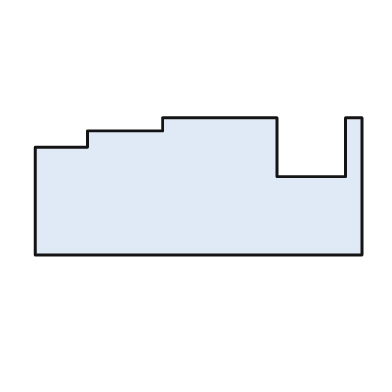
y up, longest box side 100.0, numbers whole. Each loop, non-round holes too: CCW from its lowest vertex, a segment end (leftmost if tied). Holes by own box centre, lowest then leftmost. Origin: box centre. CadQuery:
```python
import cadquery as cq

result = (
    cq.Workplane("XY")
    .moveTo(-50.0, -21.0)
    .lineTo(50.0, -21.0)
    .lineTo(50.0, 21.0)
    .lineTo(45.0, 21.0)
    .lineTo(45.0, 3.0)
    .lineTo(24.0, 3.0)
    .lineTo(24.0, 21.0)
    .lineTo(-11.0, 21.0)
    .lineTo(-11.0, 17.0)
    .lineTo(-34.0, 17.0)
    .lineTo(-34.0, 12.0)
    .lineTo(-50.0, 12.0)
    .close()
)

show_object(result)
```